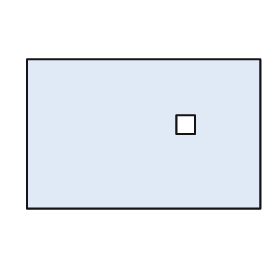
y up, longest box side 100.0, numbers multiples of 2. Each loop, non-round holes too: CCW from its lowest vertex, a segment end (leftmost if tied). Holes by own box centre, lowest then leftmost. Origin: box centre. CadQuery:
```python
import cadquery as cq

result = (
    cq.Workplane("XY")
    .moveTo(-50.0, -32.0)
    .lineTo(50.0, -32.0)
    .lineTo(50.0, 32.0)
    .lineTo(-50.0, 32.0)
    .close()
    .moveTo(14.0, 0.0)
    .lineTo(22.0, 0.0)
    .lineTo(22.0, 8.0)
    .lineTo(14.0, 8.0)
    .close()
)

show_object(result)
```